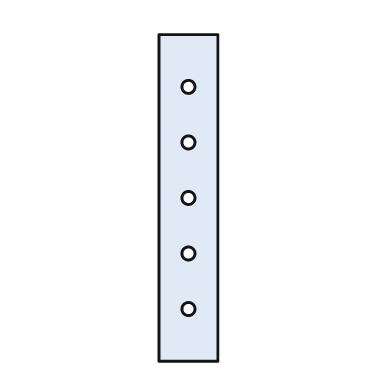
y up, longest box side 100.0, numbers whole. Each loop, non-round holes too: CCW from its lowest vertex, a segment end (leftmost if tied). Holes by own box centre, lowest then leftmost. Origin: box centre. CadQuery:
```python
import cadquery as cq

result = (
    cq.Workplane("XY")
    .moveTo(-9.0, -50.0)
    .lineTo(9.0, -50.0)
    .lineTo(9.0, 50.0)
    .lineTo(-9.0, 50.0)
    .close()
    .moveTo(0.0, -34.0)
    .circle(2.0)
    .moveTo(0.0, -17.0)
    .circle(2.0)
    .moveTo(0.0, 0.0)
    .circle(2.0)
    .moveTo(0.0, 17.0)
    .circle(2.0)
    .moveTo(0.0, 34.0)
    .circle(2.0)
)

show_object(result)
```